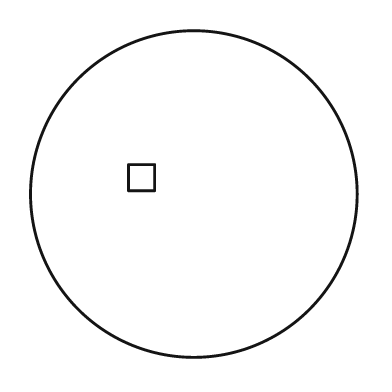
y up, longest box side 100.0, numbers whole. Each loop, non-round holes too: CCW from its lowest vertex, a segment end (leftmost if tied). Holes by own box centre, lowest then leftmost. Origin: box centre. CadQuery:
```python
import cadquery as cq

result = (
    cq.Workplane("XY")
    .moveTo(0.0, 0.0)
    .circle(50.0)
    .moveTo(-20.0, 1.0)
    .lineTo(-12.0, 1.0)
    .lineTo(-12.0, 9.0)
    .lineTo(-20.0, 9.0)
    .close()
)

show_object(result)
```